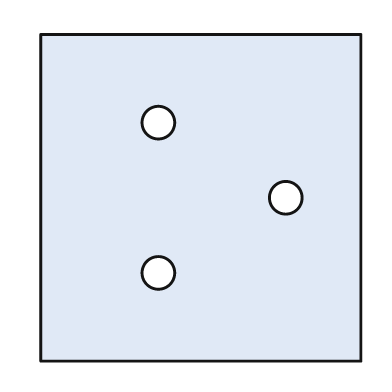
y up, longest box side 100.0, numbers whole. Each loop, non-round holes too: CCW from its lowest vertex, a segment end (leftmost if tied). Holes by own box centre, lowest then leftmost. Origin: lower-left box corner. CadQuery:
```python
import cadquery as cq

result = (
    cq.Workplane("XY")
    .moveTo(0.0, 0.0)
    .lineTo(98.0, 0.0)
    .lineTo(98.0, 100.0)
    .lineTo(0.0, 100.0)
    .close()
    .moveTo(36.0, 27.0)
    .circle(5.0)
    .moveTo(75.0, 50.0)
    .circle(5.0)
    .moveTo(36.0, 73.0)
    .circle(5.0)
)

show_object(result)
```